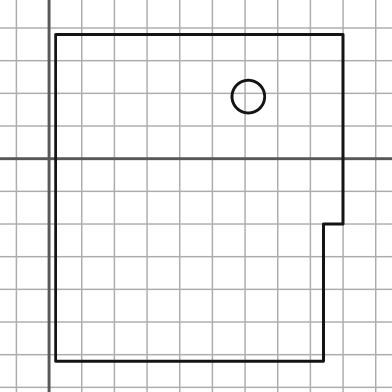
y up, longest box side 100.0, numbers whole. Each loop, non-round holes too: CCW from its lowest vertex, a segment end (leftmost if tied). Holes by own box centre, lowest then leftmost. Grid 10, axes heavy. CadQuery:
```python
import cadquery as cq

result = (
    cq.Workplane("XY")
    .moveTo(2.0, -62.0)
    .lineTo(84.0, -62.0)
    .lineTo(84.0, -20.0)
    .lineTo(90.0, -20.0)
    .lineTo(90.0, 38.0)
    .lineTo(2.0, 38.0)
    .close()
    .moveTo(61.0, 19.0)
    .circle(5.0)
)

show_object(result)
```